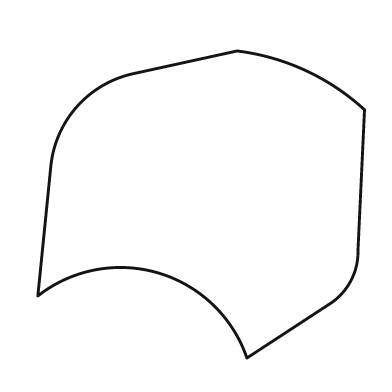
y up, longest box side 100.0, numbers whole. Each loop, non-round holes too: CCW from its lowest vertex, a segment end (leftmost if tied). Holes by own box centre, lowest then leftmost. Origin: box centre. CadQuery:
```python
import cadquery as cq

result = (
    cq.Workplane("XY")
    .moveTo(14.0, -47.0)
    .lineTo(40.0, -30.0)
    .threePointArc((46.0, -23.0), (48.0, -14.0))
    .lineTo(50.0, 29.0)
    .threePointArc((32.0, 41.0), (11.0, 47.0))
    .lineTo(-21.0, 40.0)
    .threePointArc((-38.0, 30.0), (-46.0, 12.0))
    .lineTo(-50.0, -28.0)
    .threePointArc((-13.0, -21.0), (14.0, -47.0))
    .close()
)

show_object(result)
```